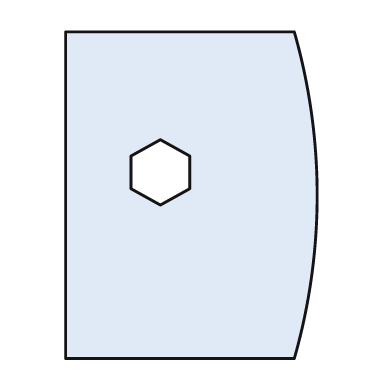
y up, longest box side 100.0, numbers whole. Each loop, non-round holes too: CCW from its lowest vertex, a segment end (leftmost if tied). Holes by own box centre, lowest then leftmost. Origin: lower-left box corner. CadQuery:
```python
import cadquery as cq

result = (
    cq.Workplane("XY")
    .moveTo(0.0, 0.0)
    .lineTo(70.0, 0.0)
    .threePointArc((77.0, 50.0), (70.0, 100.0))
    .lineTo(0.0, 100.0)
    .close()
    .moveTo(29.0, 47.0)
    .lineTo(38.0, 52.0)
    .lineTo(38.0, 62.0)
    .lineTo(29.0, 67.0)
    .lineTo(20.0, 62.0)
    .lineTo(20.0, 52.0)
    .close()
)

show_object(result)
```